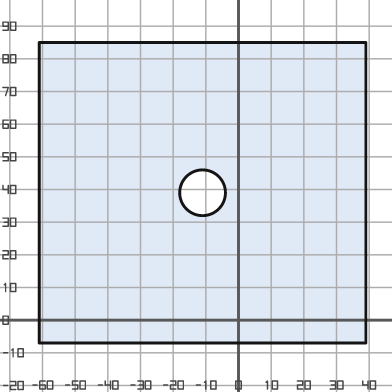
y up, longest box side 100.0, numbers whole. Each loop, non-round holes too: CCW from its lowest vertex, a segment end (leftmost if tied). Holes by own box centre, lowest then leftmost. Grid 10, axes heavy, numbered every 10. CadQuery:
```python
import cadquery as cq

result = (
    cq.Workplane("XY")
    .moveTo(-61.0, -7.0)
    .lineTo(39.0, -7.0)
    .lineTo(39.0, 85.0)
    .lineTo(-61.0, 85.0)
    .close()
    .moveTo(-11.0, 39.0)
    .circle(7.0)
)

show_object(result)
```